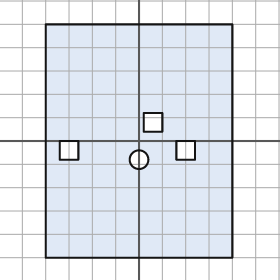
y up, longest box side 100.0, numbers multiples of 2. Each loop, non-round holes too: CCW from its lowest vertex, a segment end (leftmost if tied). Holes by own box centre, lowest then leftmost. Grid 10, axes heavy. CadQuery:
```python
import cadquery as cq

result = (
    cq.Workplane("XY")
    .moveTo(-40.0, -50.0)
    .lineTo(40.0, -50.0)
    .lineTo(40.0, 50.0)
    .lineTo(-40.0, 50.0)
    .close()
    .moveTo(0.0, -8.0)
    .circle(4.0)
    .moveTo(-34.0, -8.0)
    .lineTo(-26.0, -8.0)
    .lineTo(-26.0, 0.0)
    .lineTo(-34.0, 0.0)
    .close()
    .moveTo(16.0, -8.0)
    .lineTo(24.0, -8.0)
    .lineTo(24.0, 0.0)
    .lineTo(16.0, 0.0)
    .close()
    .moveTo(2.0, 4.0)
    .lineTo(10.0, 4.0)
    .lineTo(10.0, 12.0)
    .lineTo(2.0, 12.0)
    .close()
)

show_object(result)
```